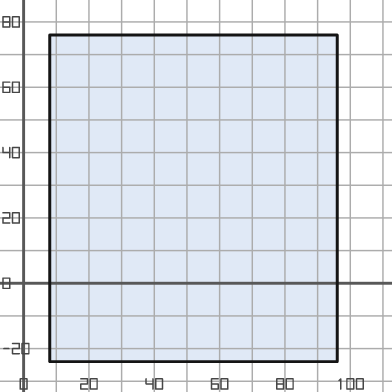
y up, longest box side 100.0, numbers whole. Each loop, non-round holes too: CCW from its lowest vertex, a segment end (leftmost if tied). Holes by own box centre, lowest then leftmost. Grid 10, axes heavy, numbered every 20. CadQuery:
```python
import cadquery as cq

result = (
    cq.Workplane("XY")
    .moveTo(8.0, -24.0)
    .lineTo(96.0, -24.0)
    .lineTo(96.0, 76.0)
    .lineTo(8.0, 76.0)
    .close()
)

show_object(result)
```